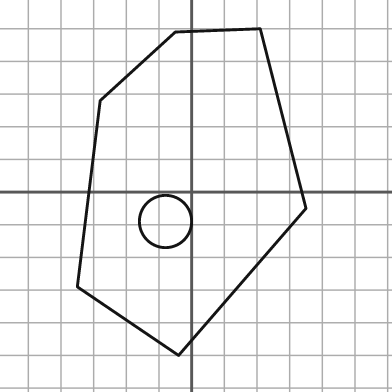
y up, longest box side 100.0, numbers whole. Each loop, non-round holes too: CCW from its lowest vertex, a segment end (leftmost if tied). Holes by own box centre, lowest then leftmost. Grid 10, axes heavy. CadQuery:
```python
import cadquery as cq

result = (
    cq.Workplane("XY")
    .moveTo(-4.0, -50.0)
    .lineTo(35.0, -5.0)
    .lineTo(21.0, 50.0)
    .lineTo(-5.0, 49.0)
    .lineTo(-28.0, 28.0)
    .lineTo(-35.0, -29.0)
    .close()
    .moveTo(-8.0, -9.0)
    .circle(8.0)
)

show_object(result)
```